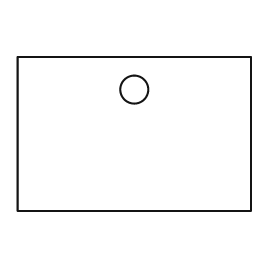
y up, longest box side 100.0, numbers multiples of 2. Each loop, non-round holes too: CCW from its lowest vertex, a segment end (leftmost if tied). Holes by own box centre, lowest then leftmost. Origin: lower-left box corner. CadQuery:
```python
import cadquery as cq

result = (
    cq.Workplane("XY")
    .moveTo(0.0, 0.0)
    .lineTo(100.0, 0.0)
    .lineTo(100.0, 66.0)
    .lineTo(0.0, 66.0)
    .close()
    .moveTo(50.0, 52.0)
    .circle(6.0)
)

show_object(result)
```